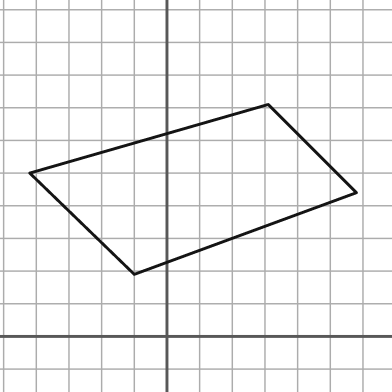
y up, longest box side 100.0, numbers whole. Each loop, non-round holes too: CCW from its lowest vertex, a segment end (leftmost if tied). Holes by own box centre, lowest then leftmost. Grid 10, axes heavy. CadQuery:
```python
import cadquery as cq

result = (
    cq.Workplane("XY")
    .moveTo(-10.0, 19.0)
    .lineTo(58.0, 44.0)
    .lineTo(31.0, 71.0)
    .lineTo(-42.0, 50.0)
    .close()
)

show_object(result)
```